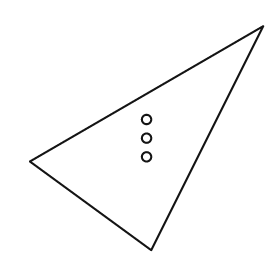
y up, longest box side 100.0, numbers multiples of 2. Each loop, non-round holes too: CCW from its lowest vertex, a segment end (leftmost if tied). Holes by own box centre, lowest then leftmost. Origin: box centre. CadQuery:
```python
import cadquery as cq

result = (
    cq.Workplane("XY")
    .moveTo(2.0, -48.0)
    .lineTo(50.0, 48.0)
    .lineTo(-50.0, -10.0)
    .close()
    .moveTo(0.0, -8.0)
    .circle(2.0)
    .moveTo(0.0, 0.0)
    .circle(2.0)
    .moveTo(0.0, 8.0)
    .circle(2.0)
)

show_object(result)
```